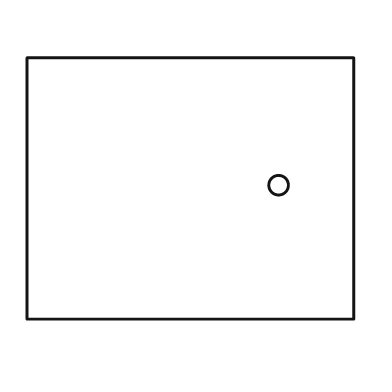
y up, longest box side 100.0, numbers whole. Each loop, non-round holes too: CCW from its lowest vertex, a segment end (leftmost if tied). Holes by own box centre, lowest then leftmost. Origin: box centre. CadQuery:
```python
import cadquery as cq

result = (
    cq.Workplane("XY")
    .moveTo(-50.0, -40.0)
    .lineTo(50.0, -40.0)
    .lineTo(50.0, 40.0)
    .lineTo(-50.0, 40.0)
    .close()
    .moveTo(27.0, 1.0)
    .circle(3.0)
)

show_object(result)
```